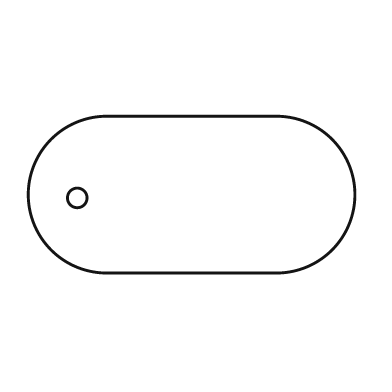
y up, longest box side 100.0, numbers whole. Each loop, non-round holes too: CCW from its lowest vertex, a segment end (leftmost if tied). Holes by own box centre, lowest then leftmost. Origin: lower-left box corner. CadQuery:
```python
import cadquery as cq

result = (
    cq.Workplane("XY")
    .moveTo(24.0, 0.0)
    .lineTo(76.0, 0.0)
    .threePointArc((100.0, 24.0), (76.0, 48.0))
    .lineTo(24.0, 48.0)
    .threePointArc((0.0, 24.0), (24.0, 0.0))
    .close()
    .moveTo(15.0, 23.0)
    .circle(3.0)
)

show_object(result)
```